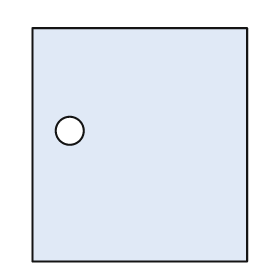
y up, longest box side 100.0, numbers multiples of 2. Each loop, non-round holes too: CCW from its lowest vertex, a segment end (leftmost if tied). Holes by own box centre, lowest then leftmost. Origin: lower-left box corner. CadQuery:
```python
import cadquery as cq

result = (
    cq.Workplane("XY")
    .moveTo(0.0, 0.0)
    .lineTo(92.0, 0.0)
    .lineTo(92.0, 100.0)
    .lineTo(0.0, 100.0)
    .close()
    .moveTo(16.0, 56.0)
    .circle(6.0)
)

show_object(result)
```